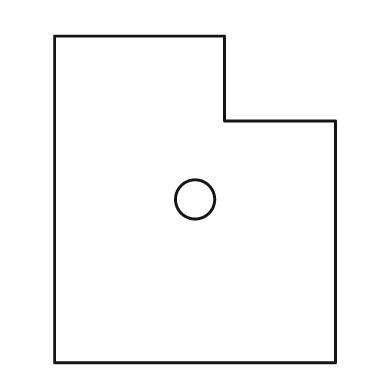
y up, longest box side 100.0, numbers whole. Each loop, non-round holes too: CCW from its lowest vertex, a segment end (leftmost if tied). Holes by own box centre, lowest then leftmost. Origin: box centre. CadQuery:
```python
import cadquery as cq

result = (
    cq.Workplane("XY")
    .moveTo(-43.0, -50.0)
    .lineTo(43.0, -50.0)
    .lineTo(43.0, 24.0)
    .lineTo(9.0, 24.0)
    .lineTo(9.0, 50.0)
    .lineTo(-43.0, 50.0)
    .close()
    .moveTo(0.0, 0.0)
    .circle(6.0)
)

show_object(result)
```